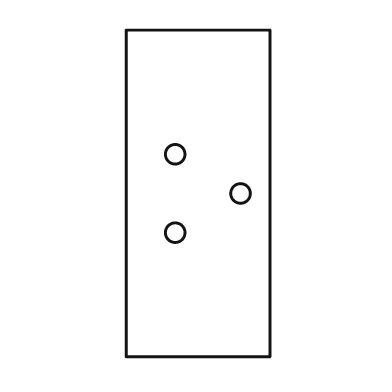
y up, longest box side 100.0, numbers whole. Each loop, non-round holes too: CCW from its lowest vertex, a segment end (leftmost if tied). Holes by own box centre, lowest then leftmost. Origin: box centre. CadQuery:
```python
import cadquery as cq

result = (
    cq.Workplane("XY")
    .moveTo(-22.0, -50.0)
    .lineTo(22.0, -50.0)
    .lineTo(22.0, 50.0)
    .lineTo(-22.0, 50.0)
    .close()
    .moveTo(-7.0, -12.0)
    .circle(3.0)
    .moveTo(13.0, 0.0)
    .circle(3.0)
    .moveTo(-7.0, 12.0)
    .circle(3.0)
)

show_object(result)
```